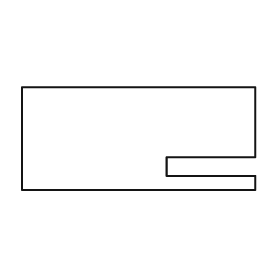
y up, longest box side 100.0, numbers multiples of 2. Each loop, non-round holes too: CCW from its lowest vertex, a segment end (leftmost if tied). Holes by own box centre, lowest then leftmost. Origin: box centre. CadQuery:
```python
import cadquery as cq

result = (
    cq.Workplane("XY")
    .moveTo(-50.0, -22.0)
    .lineTo(50.0, -22.0)
    .lineTo(50.0, -16.0)
    .lineTo(12.0, -16.0)
    .lineTo(12.0, -8.0)
    .lineTo(50.0, -8.0)
    .lineTo(50.0, 22.0)
    .lineTo(-50.0, 22.0)
    .close()
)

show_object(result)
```